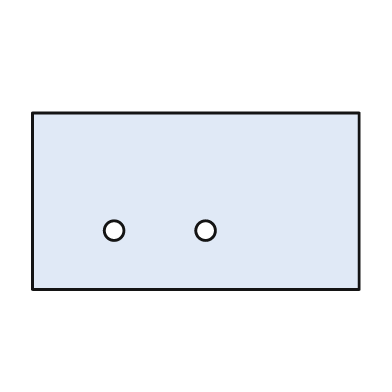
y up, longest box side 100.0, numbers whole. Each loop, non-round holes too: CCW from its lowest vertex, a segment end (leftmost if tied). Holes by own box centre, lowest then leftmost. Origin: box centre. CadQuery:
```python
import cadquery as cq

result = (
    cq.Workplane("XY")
    .moveTo(-50.0, -27.0)
    .lineTo(50.0, -27.0)
    .lineTo(50.0, 27.0)
    .lineTo(-50.0, 27.0)
    .close()
    .moveTo(-25.0, -9.0)
    .circle(3.0)
    .moveTo(3.0, -9.0)
    .circle(3.0)
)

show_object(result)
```